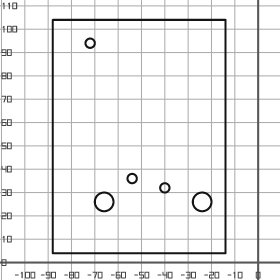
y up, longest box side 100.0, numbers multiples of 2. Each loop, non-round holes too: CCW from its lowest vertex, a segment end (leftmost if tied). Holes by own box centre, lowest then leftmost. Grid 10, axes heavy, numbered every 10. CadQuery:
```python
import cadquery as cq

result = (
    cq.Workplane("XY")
    .moveTo(-88.0, 4.0)
    .lineTo(-14.0, 4.0)
    .lineTo(-14.0, 104.0)
    .lineTo(-88.0, 104.0)
    .close()
    .moveTo(-66.0, 26.0)
    .circle(4.0)
    .moveTo(-24.0, 26.0)
    .circle(4.0)
    .moveTo(-40.0, 32.0)
    .circle(2.0)
    .moveTo(-54.0, 36.0)
    .circle(2.0)
    .moveTo(-72.0, 94.0)
    .circle(2.0)
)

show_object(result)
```